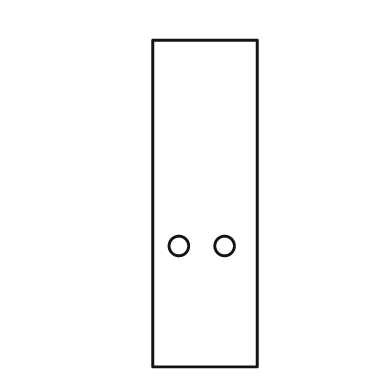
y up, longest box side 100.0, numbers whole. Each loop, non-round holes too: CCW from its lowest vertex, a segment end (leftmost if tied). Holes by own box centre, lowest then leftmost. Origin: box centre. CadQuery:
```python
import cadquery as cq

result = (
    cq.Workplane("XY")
    .moveTo(-16.0, -50.0)
    .lineTo(16.0, -50.0)
    .lineTo(16.0, 50.0)
    .lineTo(-16.0, 50.0)
    .close()
    .moveTo(-8.0, -13.0)
    .circle(3.0)
    .moveTo(6.0, -13.0)
    .circle(3.0)
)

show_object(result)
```